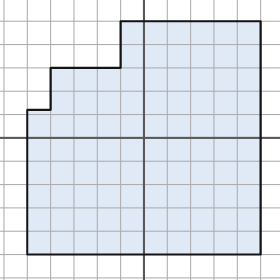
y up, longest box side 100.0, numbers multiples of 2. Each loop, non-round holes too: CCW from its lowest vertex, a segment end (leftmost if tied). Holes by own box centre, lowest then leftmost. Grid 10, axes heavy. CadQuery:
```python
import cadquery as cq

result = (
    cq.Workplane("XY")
    .moveTo(-50.0, -50.0)
    .lineTo(50.0, -50.0)
    .lineTo(50.0, 50.0)
    .lineTo(-10.0, 50.0)
    .lineTo(-10.0, 30.0)
    .lineTo(-40.0, 30.0)
    .lineTo(-40.0, 12.0)
    .lineTo(-50.0, 12.0)
    .close()
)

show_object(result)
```